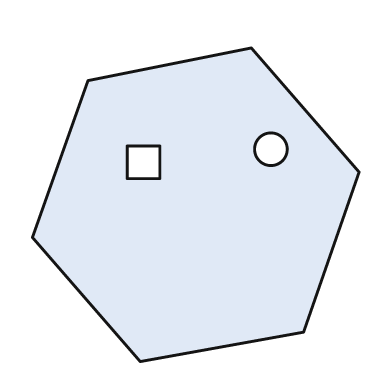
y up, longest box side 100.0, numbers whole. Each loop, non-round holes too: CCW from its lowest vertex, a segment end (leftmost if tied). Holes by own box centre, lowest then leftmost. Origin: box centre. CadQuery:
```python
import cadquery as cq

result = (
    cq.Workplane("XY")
    .moveTo(-17.0, -48.0)
    .lineTo(33.0, -39.0)
    .lineTo(50.0, 10.0)
    .lineTo(17.0, 48.0)
    .lineTo(-33.0, 38.0)
    .lineTo(-50.0, -10.0)
    .close()
    .moveTo(-21.0, 8.0)
    .lineTo(-11.0, 8.0)
    .lineTo(-11.0, 18.0)
    .lineTo(-21.0, 18.0)
    .close()
    .moveTo(23.0, 17.0)
    .circle(5.0)
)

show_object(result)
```